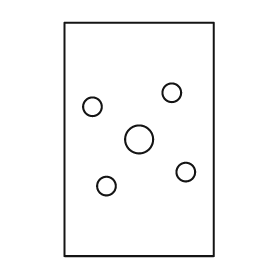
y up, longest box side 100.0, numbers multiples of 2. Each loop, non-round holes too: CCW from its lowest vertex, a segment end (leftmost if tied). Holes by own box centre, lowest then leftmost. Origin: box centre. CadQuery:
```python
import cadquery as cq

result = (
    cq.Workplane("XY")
    .moveTo(-32.0, -50.0)
    .lineTo(32.0, -50.0)
    .lineTo(32.0, 50.0)
    .lineTo(-32.0, 50.0)
    .close()
    .moveTo(-14.0, -20.0)
    .circle(4.0)
    .moveTo(20.0, -14.0)
    .circle(4.0)
    .moveTo(0.0, 0.0)
    .circle(6.0)
    .moveTo(-20.0, 14.0)
    .circle(4.0)
    .moveTo(14.0, 20.0)
    .circle(4.0)
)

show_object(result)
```